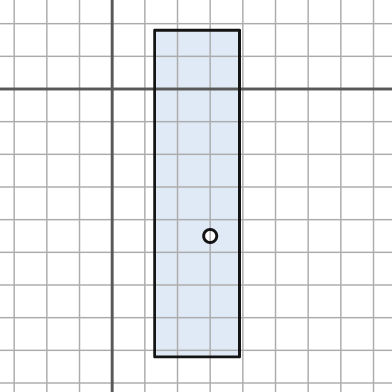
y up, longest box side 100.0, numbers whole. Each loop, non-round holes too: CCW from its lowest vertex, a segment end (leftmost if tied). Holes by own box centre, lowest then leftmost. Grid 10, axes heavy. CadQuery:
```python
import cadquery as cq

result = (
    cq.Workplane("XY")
    .moveTo(13.0, -82.0)
    .lineTo(39.0, -82.0)
    .lineTo(39.0, 18.0)
    .lineTo(13.0, 18.0)
    .close()
    .moveTo(30.0, -45.0)
    .circle(2.0)
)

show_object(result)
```